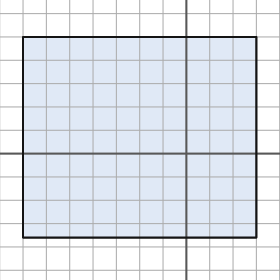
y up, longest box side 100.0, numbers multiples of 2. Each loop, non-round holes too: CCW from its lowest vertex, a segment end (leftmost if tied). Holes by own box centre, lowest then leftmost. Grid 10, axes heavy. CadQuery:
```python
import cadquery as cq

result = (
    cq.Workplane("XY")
    .moveTo(-70.0, -36.0)
    .lineTo(30.0, -36.0)
    .lineTo(30.0, 50.0)
    .lineTo(-70.0, 50.0)
    .close()
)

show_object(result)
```